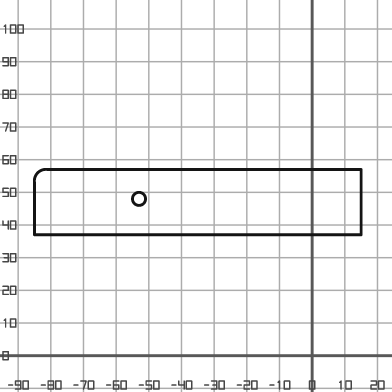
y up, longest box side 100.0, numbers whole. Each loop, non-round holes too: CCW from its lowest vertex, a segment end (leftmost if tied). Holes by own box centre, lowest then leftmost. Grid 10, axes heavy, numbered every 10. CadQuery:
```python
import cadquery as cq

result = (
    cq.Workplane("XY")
    .moveTo(-85.0, 37.0)
    .lineTo(15.0, 37.0)
    .lineTo(15.0, 57.0)
    .lineTo(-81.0, 57.0)
    .threePointArc((-84.0, 56.0), (-85.0, 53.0))
    .close()
    .moveTo(-53.0, 48.0)
    .circle(2.0)
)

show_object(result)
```